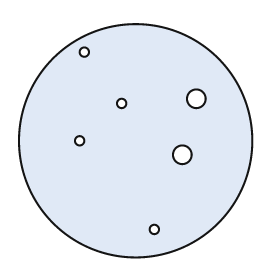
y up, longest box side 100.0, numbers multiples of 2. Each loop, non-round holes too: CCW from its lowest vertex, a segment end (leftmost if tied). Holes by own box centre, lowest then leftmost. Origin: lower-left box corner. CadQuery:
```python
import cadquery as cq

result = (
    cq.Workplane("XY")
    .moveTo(50.0, 50.0)
    .circle(50.0)
    .moveTo(58.0, 12.0)
    .circle(2.0)
    .moveTo(70.0, 44.0)
    .circle(4.0)
    .moveTo(26.0, 50.0)
    .circle(2.0)
    .moveTo(44.0, 66.0)
    .circle(2.0)
    .moveTo(76.0, 68.0)
    .circle(4.0)
    .moveTo(28.0, 88.0)
    .circle(2.0)
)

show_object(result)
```